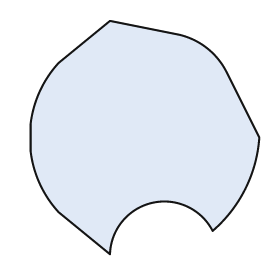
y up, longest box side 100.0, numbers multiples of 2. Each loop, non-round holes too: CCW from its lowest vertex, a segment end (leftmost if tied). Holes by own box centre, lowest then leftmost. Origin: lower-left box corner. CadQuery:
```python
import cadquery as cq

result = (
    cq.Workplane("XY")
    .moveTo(34.0, 0.0)
    .threePointArc((52.0, 22.0), (78.0, 10.0))
    .threePointArc((92.0, 28.0), (98.0, 50.0))
    .lineTo(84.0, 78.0)
    .threePointArc((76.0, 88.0), (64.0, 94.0))
    .lineTo(34.0, 100.0)
    .lineTo(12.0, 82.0)
    .threePointArc((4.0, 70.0), (0.0, 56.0))
    .lineTo(0.0, 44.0)
    .threePointArc((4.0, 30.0), (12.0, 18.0))
    .close()
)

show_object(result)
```